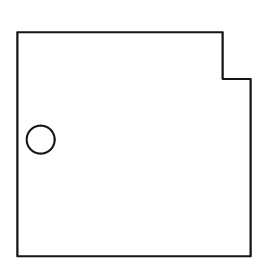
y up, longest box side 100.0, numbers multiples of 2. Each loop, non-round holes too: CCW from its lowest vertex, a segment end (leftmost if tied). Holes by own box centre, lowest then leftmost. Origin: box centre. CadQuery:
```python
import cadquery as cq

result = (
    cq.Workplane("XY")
    .moveTo(-50.0, -48.0)
    .lineTo(50.0, -48.0)
    .lineTo(50.0, 28.0)
    .lineTo(38.0, 28.0)
    .lineTo(38.0, 48.0)
    .lineTo(-50.0, 48.0)
    .close()
    .moveTo(-40.0, 2.0)
    .circle(6.0)
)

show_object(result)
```